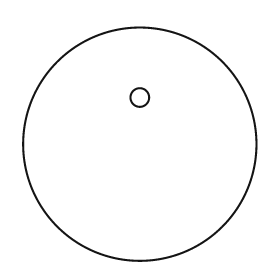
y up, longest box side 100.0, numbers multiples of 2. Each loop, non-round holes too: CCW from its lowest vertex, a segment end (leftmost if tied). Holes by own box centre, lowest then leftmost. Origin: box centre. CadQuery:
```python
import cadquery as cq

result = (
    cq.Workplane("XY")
    .moveTo(0.0, 0.0)
    .circle(50.0)
    .moveTo(0.0, 20.0)
    .circle(4.0)
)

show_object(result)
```